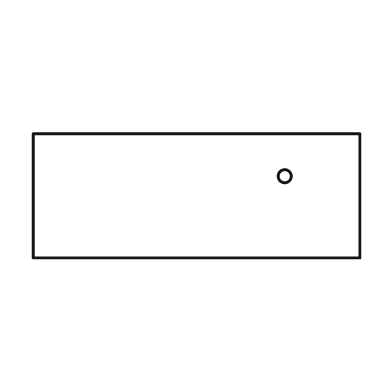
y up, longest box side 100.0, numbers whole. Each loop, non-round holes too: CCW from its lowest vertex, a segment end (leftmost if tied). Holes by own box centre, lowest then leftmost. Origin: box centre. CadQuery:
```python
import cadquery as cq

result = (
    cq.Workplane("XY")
    .moveTo(-50.0, -19.0)
    .lineTo(50.0, -19.0)
    .lineTo(50.0, 19.0)
    .lineTo(-50.0, 19.0)
    .close()
    .moveTo(27.0, 6.0)
    .circle(2.0)
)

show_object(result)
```